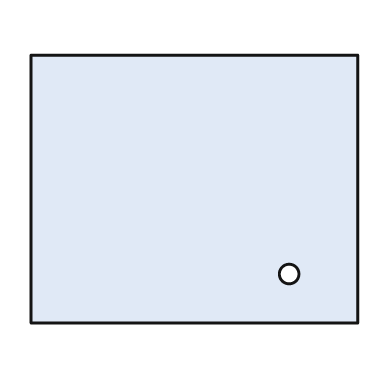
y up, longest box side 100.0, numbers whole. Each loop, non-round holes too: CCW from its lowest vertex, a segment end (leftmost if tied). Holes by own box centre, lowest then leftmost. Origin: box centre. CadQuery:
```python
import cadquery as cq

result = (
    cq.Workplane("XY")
    .moveTo(-50.0, -41.0)
    .lineTo(50.0, -41.0)
    .lineTo(50.0, 41.0)
    .lineTo(-50.0, 41.0)
    .close()
    .moveTo(29.0, -26.0)
    .circle(3.0)
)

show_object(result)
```